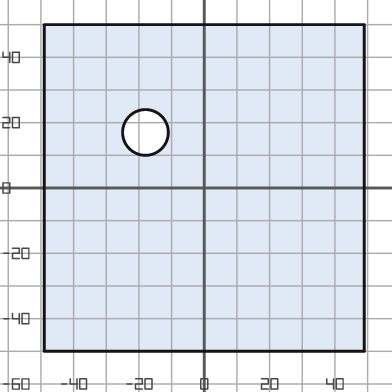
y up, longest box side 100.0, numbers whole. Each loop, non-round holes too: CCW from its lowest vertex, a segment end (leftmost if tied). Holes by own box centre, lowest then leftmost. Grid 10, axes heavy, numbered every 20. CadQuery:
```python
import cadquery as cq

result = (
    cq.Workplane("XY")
    .moveTo(-49.0, -50.0)
    .lineTo(49.0, -50.0)
    .lineTo(49.0, 50.0)
    .lineTo(-49.0, 50.0)
    .close()
    .moveTo(-18.0, 17.0)
    .circle(7.0)
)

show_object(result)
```